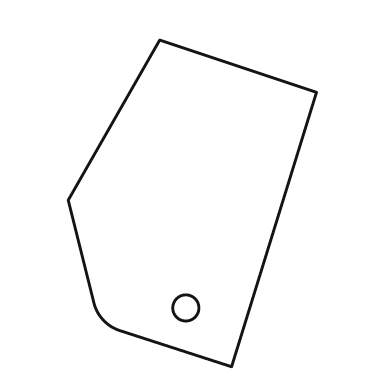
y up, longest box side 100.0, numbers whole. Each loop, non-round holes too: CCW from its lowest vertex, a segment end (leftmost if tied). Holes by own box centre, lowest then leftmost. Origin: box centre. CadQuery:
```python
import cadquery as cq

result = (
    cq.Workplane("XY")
    .moveTo(12.0, -50.0)
    .lineTo(38.0, 34.0)
    .lineTo(-10.0, 50.0)
    .lineTo(-38.0, 1.0)
    .lineTo(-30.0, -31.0)
    .threePointArc((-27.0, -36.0), (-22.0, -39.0))
    .close()
    .moveTo(-2.0, -32.0)
    .circle(4.0)
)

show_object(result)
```